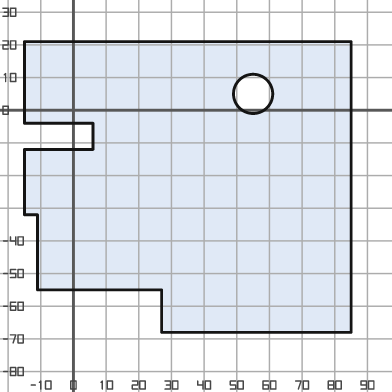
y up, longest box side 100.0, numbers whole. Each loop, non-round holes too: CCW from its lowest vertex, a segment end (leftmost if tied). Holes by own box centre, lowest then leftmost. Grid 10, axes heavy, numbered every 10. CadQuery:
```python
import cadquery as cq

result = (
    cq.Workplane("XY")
    .moveTo(27.0, -68.0)
    .lineTo(85.0, -68.0)
    .lineTo(85.0, 21.0)
    .lineTo(-15.0, 21.0)
    .lineTo(-15.0, -4.0)
    .lineTo(6.0, -4.0)
    .lineTo(6.0, -12.0)
    .lineTo(-15.0, -12.0)
    .lineTo(-15.0, -32.0)
    .lineTo(-11.0, -32.0)
    .lineTo(-11.0, -55.0)
    .lineTo(27.0, -55.0)
    .close()
    .moveTo(55.0, 5.0)
    .circle(6.0)
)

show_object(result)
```